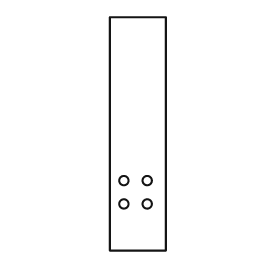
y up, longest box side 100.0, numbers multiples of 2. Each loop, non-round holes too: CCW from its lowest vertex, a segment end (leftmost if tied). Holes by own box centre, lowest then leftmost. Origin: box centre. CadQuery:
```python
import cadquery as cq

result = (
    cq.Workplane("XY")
    .moveTo(-12.0, -50.0)
    .lineTo(12.0, -50.0)
    .lineTo(12.0, 50.0)
    .lineTo(-12.0, 50.0)
    .close()
    .moveTo(-6.0, -30.0)
    .circle(2.0)
    .moveTo(4.0, -30.0)
    .circle(2.0)
    .moveTo(-6.0, -20.0)
    .circle(2.0)
    .moveTo(4.0, -20.0)
    .circle(2.0)
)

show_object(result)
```